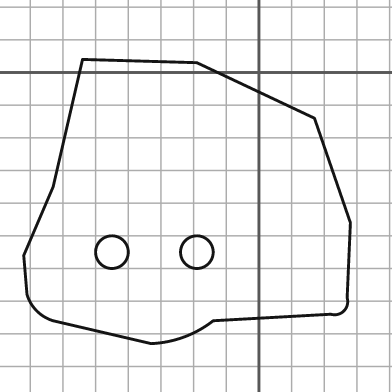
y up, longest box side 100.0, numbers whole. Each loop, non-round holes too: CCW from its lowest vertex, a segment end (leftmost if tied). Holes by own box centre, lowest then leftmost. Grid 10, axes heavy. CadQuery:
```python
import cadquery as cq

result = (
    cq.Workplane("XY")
    .moveTo(-33.0, -83.0)
    .threePointArc((-23.0, -81.0), (-14.0, -76.0))
    .lineTo(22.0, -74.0)
    .threePointArc((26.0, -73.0), (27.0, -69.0))
    .lineTo(28.0, -46.0)
    .lineTo(17.0, -14.0)
    .lineTo(-19.0, 3.0)
    .lineTo(-54.0, 4.0)
    .lineTo(-63.0, -35.0)
    .lineTo(-72.0, -56.0)
    .lineTo(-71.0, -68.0)
    .threePointArc((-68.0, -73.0), (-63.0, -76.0))
    .close()
    .moveTo(-45.0, -55.0)
    .circle(5.0)
    .moveTo(-19.0, -55.0)
    .circle(5.0)
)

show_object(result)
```